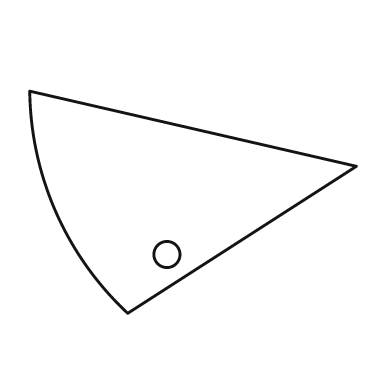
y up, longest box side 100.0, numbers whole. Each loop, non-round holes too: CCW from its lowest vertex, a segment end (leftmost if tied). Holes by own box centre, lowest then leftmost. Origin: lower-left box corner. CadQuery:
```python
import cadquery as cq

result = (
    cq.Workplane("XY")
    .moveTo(30.0, 0.0)
    .lineTo(100.0, 45.0)
    .lineTo(0.0, 68.0)
    .threePointArc((8.0, 31.0), (30.0, 0.0))
    .close()
    .moveTo(42.0, 18.0)
    .circle(4.0)
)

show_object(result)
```